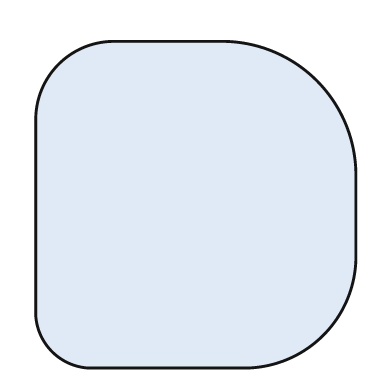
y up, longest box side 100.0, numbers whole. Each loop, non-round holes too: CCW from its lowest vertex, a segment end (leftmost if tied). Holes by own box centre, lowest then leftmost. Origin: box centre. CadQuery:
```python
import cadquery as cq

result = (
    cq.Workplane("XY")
    .moveTo(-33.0, -50.0)
    .lineTo(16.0, -50.0)
    .threePointArc((39.0, -40.0), (49.0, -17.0))
    .lineTo(49.0, 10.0)
    .threePointArc((37.0, 38.0), (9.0, 50.0))
    .lineTo(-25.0, 50.0)
    .threePointArc((-42.0, 43.0), (-49.0, 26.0))
    .lineTo(-49.0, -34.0)
    .threePointArc((-44.0, -45.0), (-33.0, -50.0))
    .close()
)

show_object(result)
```